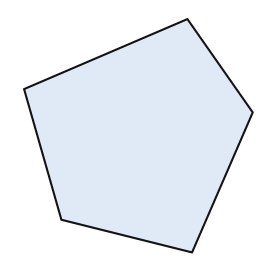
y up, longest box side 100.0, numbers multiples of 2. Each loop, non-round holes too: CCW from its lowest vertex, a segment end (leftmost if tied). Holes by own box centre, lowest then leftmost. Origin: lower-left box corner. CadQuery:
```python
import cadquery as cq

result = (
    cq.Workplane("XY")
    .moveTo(72.0, 0.0)
    .lineTo(98.0, 60.0)
    .lineTo(70.0, 100.0)
    .lineTo(0.0, 70.0)
    .lineTo(16.0, 14.0)
    .close()
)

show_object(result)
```